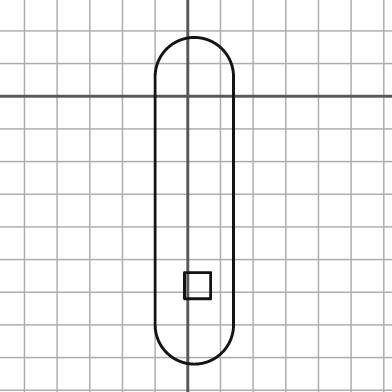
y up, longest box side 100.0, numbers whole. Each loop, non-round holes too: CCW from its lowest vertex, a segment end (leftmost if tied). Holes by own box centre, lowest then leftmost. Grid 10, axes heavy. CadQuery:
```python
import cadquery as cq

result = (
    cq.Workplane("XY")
    .moveTo(-10.0, -70.0)
    .threePointArc((2.0, -82.0), (14.0, -70.0))
    .lineTo(14.0, 6.0)
    .threePointArc((2.0, 18.0), (-10.0, 6.0))
    .close()
    .moveTo(-1.0, -62.0)
    .lineTo(7.0, -62.0)
    .lineTo(7.0, -54.0)
    .lineTo(-1.0, -54.0)
    .close()
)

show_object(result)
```